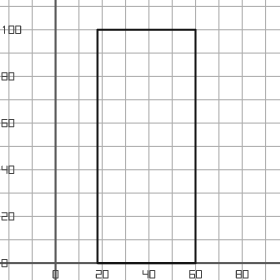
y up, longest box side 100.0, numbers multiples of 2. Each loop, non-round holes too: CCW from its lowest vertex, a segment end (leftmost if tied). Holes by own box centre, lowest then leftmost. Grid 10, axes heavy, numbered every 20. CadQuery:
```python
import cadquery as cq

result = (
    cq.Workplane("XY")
    .moveTo(18.0, 0.0)
    .lineTo(60.0, 0.0)
    .lineTo(60.0, 100.0)
    .lineTo(18.0, 100.0)
    .close()
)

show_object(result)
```